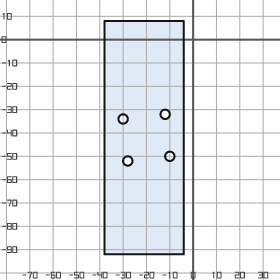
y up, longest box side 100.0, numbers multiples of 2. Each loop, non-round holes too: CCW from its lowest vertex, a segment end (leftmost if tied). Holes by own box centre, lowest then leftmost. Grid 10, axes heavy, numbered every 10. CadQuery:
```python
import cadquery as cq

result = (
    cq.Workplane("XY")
    .moveTo(-38.0, -92.0)
    .lineTo(-4.0, -92.0)
    .lineTo(-4.0, 8.0)
    .lineTo(-38.0, 8.0)
    .close()
    .moveTo(-28.0, -52.0)
    .circle(2.0)
    .moveTo(-10.0, -50.0)
    .circle(2.0)
    .moveTo(-30.0, -34.0)
    .circle(2.0)
    .moveTo(-12.0, -32.0)
    .circle(2.0)
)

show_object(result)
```